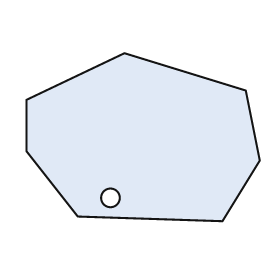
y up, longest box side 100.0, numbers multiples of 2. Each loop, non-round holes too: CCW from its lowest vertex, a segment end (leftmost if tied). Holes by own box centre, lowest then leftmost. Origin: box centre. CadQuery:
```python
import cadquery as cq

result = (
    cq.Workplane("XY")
    .moveTo(34.0, -36.0)
    .lineTo(50.0, -10.0)
    .lineTo(44.0, 20.0)
    .lineTo(-8.0, 36.0)
    .lineTo(-50.0, 16.0)
    .lineTo(-50.0, -6.0)
    .lineTo(-28.0, -34.0)
    .close()
    .moveTo(-14.0, -26.0)
    .circle(4.0)
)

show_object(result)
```